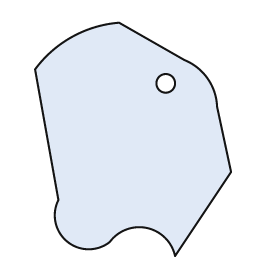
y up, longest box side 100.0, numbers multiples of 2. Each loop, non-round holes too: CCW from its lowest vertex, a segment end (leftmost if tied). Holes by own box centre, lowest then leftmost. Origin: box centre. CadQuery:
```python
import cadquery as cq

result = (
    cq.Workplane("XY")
    .moveTo(18.0, -50.0)
    .lineTo(42.0, -14.0)
    .lineTo(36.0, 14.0)
    .threePointArc((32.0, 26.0), (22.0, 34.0))
    .lineTo(-6.0, 50.0)
    .threePointArc((-26.0, 44.0), (-42.0, 30.0))
    .lineTo(-32.0, -26.0)
    .threePointArc((-28.0, -44.0), (-10.0, -44.0))
    .threePointArc((6.0, -38.0), (18.0, -50.0))
    .close()
    .moveTo(14.0, 24.0)
    .circle(4.0)
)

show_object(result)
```